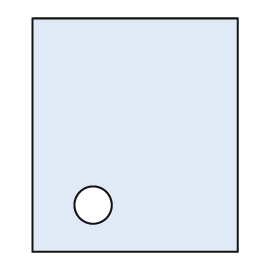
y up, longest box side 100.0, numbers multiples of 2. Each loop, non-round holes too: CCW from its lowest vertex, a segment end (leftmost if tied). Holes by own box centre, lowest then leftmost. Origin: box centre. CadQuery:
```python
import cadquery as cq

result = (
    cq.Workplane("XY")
    .moveTo(-44.0, -50.0)
    .lineTo(44.0, -50.0)
    .lineTo(44.0, 50.0)
    .lineTo(-44.0, 50.0)
    .close()
    .moveTo(-18.0, -30.0)
    .circle(8.0)
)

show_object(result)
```